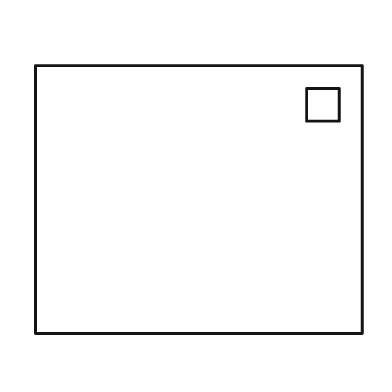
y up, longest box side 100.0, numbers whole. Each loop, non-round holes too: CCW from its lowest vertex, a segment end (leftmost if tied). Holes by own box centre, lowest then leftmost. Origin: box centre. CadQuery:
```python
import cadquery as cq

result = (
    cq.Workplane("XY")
    .moveTo(-50.0, -41.0)
    .lineTo(50.0, -41.0)
    .lineTo(50.0, 41.0)
    .lineTo(-50.0, 41.0)
    .close()
    .moveTo(33.0, 24.0)
    .lineTo(43.0, 24.0)
    .lineTo(43.0, 34.0)
    .lineTo(33.0, 34.0)
    .close()
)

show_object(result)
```